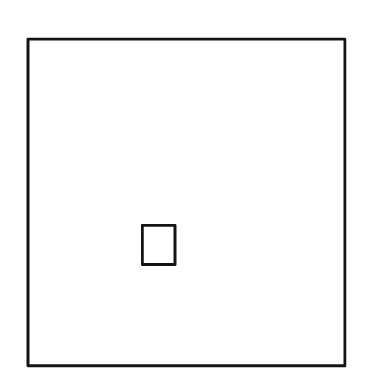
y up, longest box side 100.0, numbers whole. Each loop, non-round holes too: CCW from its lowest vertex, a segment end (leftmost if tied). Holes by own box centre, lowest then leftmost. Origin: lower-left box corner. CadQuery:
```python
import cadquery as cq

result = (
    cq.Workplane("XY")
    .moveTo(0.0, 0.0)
    .lineTo(97.0, 0.0)
    .lineTo(97.0, 100.0)
    .lineTo(0.0, 100.0)
    .close()
    .moveTo(35.0, 31.0)
    .lineTo(45.0, 31.0)
    .lineTo(45.0, 43.0)
    .lineTo(35.0, 43.0)
    .close()
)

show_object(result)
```